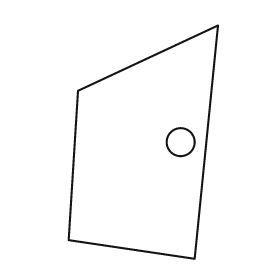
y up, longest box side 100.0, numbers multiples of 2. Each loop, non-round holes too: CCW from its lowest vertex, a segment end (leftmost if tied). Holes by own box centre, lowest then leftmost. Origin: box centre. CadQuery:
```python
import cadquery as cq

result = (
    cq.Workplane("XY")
    .moveTo(22.0, -50.0)
    .lineTo(32.0, 50.0)
    .lineTo(-28.0, 22.0)
    .lineTo(-32.0, -42.0)
    .close()
    .moveTo(16.0, 0.0)
    .circle(6.0)
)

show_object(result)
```